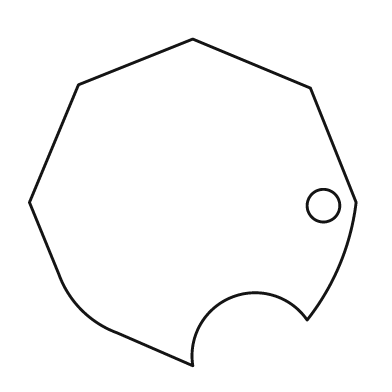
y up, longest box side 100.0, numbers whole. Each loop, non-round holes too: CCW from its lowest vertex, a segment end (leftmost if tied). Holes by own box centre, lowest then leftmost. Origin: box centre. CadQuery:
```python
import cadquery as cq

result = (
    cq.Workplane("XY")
    .moveTo(0.0, -50.0)
    .threePointArc((12.0, -29.0), (35.0, -36.0))
    .threePointArc((45.0, -19.0), (50.0, 0.0))
    .lineTo(36.0, 35.0)
    .lineTo(0.0, 50.0)
    .lineTo(-35.0, 36.0)
    .lineTo(-50.0, 0.0)
    .lineTo(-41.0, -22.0)
    .threePointArc((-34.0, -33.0), (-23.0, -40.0))
    .close()
    .moveTo(40.0, -1.0)
    .circle(5.0)
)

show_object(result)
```